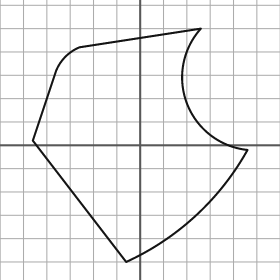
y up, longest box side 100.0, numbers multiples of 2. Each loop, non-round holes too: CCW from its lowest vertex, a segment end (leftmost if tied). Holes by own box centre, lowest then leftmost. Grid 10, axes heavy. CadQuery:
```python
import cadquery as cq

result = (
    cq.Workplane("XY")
    .moveTo(-6.0, -50.0)
    .threePointArc((24.0, -30.0), (46.0, -2.0))
    .threePointArc((20.0, 18.0), (26.0, 50.0))
    .lineTo(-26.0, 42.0)
    .threePointArc((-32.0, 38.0), (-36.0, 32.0))
    .lineTo(-46.0, 2.0)
    .close()
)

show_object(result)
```